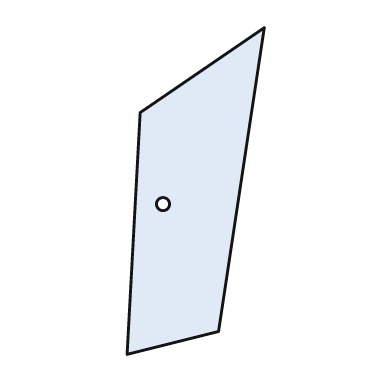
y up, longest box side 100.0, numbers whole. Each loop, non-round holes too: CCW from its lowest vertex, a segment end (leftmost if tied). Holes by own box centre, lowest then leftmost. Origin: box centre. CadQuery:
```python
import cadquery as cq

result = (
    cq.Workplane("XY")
    .moveTo(-21.0, -50.0)
    .lineTo(7.0, -43.0)
    .lineTo(21.0, 50.0)
    .lineTo(-17.0, 24.0)
    .close()
    .moveTo(-10.0, -4.0)
    .circle(2.0)
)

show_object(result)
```